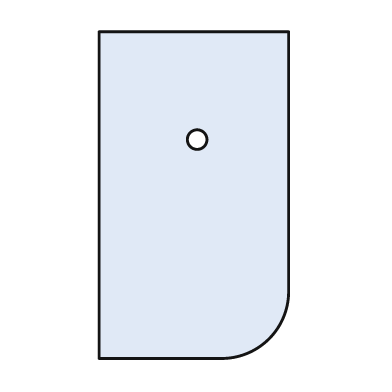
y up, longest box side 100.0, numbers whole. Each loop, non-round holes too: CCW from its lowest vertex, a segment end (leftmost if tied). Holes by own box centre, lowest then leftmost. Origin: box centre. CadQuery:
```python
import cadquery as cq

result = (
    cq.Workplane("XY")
    .moveTo(-29.0, -50.0)
    .lineTo(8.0, -50.0)
    .threePointArc((23.0, -44.0), (29.0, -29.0))
    .lineTo(29.0, 50.0)
    .lineTo(-29.0, 50.0)
    .close()
    .moveTo(1.0, 17.0)
    .circle(3.0)
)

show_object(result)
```